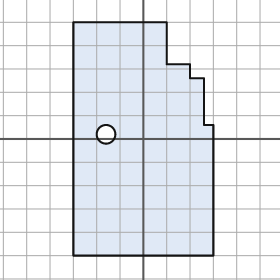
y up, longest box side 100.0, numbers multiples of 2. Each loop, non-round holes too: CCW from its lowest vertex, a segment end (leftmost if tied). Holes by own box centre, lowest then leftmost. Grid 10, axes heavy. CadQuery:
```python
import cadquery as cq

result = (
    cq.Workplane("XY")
    .moveTo(-30.0, -50.0)
    .lineTo(30.0, -50.0)
    .lineTo(30.0, 6.0)
    .lineTo(26.0, 6.0)
    .lineTo(26.0, 26.0)
    .lineTo(20.0, 26.0)
    .lineTo(20.0, 32.0)
    .lineTo(10.0, 32.0)
    .lineTo(10.0, 50.0)
    .lineTo(-30.0, 50.0)
    .close()
    .moveTo(-16.0, 2.0)
    .circle(4.0)
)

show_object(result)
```